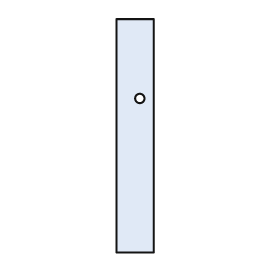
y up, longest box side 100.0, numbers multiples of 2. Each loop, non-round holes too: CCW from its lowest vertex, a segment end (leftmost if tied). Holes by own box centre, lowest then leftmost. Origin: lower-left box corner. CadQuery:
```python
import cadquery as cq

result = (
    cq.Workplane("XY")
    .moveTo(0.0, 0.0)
    .lineTo(16.0, 0.0)
    .lineTo(16.0, 100.0)
    .lineTo(0.0, 100.0)
    .close()
    .moveTo(10.0, 66.0)
    .circle(2.0)
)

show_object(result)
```